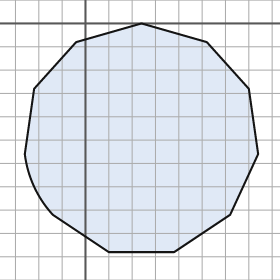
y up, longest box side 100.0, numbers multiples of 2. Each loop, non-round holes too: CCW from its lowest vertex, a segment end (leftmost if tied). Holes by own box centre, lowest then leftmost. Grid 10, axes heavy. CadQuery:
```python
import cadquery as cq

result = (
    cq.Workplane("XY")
    .moveTo(10.0, -98.0)
    .lineTo(38.0, -98.0)
    .lineTo(62.0, -82.0)
    .lineTo(74.0, -56.0)
    .lineTo(70.0, -28.0)
    .lineTo(52.0, -8.0)
    .lineTo(24.0, 0.0)
    .lineTo(-4.0, -8.0)
    .lineTo(-22.0, -28.0)
    .lineTo(-26.0, -56.0)
    .threePointArc((-22.0, -70.0), (-14.0, -82.0))
    .close()
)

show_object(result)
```